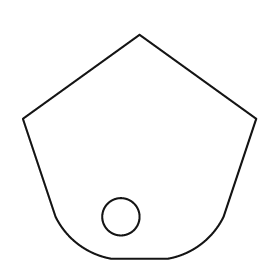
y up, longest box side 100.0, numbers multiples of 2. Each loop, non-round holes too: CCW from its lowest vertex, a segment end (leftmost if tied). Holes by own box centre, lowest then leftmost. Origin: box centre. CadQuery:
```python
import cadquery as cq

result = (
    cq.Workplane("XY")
    .moveTo(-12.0, -48.0)
    .lineTo(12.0, -48.0)
    .threePointArc((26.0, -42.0), (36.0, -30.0))
    .lineTo(50.0, 12.0)
    .lineTo(0.0, 48.0)
    .lineTo(-50.0, 12.0)
    .lineTo(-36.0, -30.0)
    .threePointArc((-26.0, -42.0), (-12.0, -48.0))
    .close()
    .moveTo(-8.0, -30.0)
    .circle(8.0)
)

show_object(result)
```